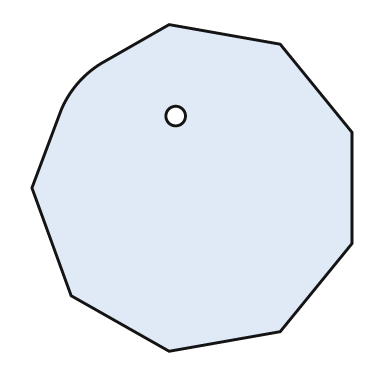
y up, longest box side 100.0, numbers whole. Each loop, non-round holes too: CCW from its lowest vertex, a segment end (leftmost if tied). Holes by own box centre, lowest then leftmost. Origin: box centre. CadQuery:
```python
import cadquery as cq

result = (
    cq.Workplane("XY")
    .moveTo(-7.0, -50.0)
    .lineTo(27.0, -44.0)
    .lineTo(49.0, -17.0)
    .lineTo(49.0, 17.0)
    .lineTo(27.0, 44.0)
    .lineTo(-7.0, 50.0)
    .lineTo(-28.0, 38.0)
    .threePointArc((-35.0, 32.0), (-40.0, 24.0))
    .lineTo(-49.0, 0.0)
    .lineTo(-37.0, -33.0)
    .close()
    .moveTo(-5.0, 22.0)
    .circle(3.0)
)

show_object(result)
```